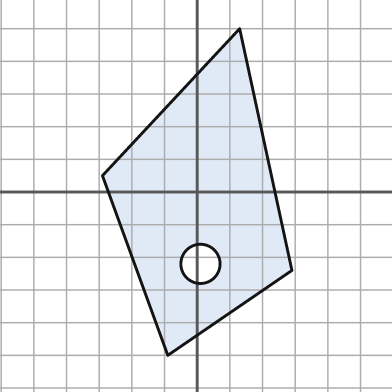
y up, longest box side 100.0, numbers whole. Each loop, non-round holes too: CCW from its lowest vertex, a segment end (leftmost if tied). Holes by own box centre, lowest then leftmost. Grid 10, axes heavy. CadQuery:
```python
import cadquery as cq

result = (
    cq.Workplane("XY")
    .moveTo(-9.0, -50.0)
    .lineTo(29.0, -24.0)
    .lineTo(13.0, 50.0)
    .lineTo(-29.0, 5.0)
    .close()
    .moveTo(1.0, -22.0)
    .circle(6.0)
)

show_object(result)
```